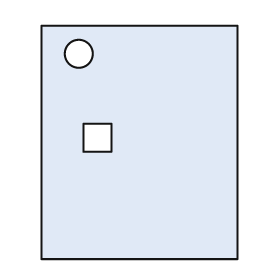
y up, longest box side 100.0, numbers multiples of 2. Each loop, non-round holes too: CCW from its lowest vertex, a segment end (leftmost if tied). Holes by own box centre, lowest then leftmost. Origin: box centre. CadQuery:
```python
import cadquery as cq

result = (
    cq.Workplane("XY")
    .moveTo(-42.0, -50.0)
    .lineTo(42.0, -50.0)
    .lineTo(42.0, 50.0)
    .lineTo(-42.0, 50.0)
    .close()
    .moveTo(-24.0, -4.0)
    .lineTo(-12.0, -4.0)
    .lineTo(-12.0, 8.0)
    .lineTo(-24.0, 8.0)
    .close()
    .moveTo(-26.0, 38.0)
    .circle(6.0)
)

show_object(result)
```